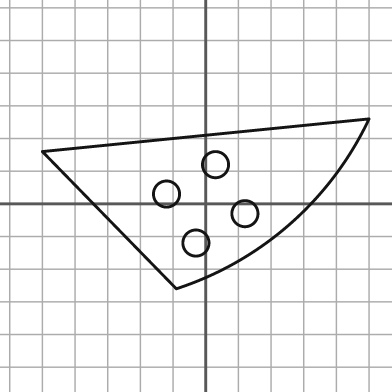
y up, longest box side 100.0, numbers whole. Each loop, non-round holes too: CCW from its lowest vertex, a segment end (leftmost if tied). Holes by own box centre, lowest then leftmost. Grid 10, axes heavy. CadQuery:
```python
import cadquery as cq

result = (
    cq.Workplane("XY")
    .moveTo(-9.0, -26.0)
    .threePointArc((26.0, -6.0), (50.0, 26.0))
    .lineTo(-50.0, 16.0)
    .close()
    .moveTo(-3.0, -12.0)
    .circle(4.0)
    .moveTo(12.0, -3.0)
    .circle(4.0)
    .moveTo(-12.0, 3.0)
    .circle(4.0)
    .moveTo(3.0, 12.0)
    .circle(4.0)
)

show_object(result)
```